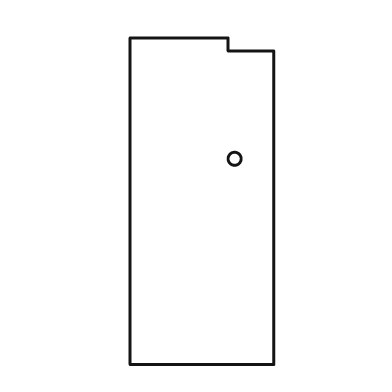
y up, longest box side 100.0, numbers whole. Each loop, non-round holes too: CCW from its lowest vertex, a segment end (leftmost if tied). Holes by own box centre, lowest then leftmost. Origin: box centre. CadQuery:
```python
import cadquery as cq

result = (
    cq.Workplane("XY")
    .moveTo(-22.0, -50.0)
    .lineTo(22.0, -50.0)
    .lineTo(22.0, 46.0)
    .lineTo(8.0, 46.0)
    .lineTo(8.0, 50.0)
    .lineTo(-22.0, 50.0)
    .close()
    .moveTo(10.0, 13.0)
    .circle(2.0)
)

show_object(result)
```